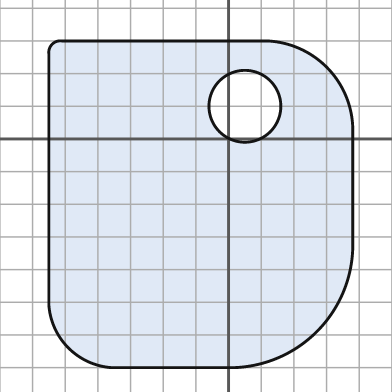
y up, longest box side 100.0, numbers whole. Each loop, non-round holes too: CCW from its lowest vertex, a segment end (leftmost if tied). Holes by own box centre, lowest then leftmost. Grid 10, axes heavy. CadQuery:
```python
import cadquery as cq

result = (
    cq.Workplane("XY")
    .moveTo(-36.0, -70.0)
    .lineTo(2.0, -70.0)
    .threePointArc((27.0, -59.0), (38.0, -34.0))
    .lineTo(38.0, 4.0)
    .threePointArc((30.0, 22.0), (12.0, 30.0))
    .lineTo(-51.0, 30.0)
    .threePointArc((-54.0, 29.0), (-55.0, 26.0))
    .lineTo(-55.0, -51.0)
    .threePointArc((-49.0, -64.0), (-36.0, -70.0))
    .close()
    .moveTo(5.0, 10.0)
    .circle(11.0)
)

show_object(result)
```